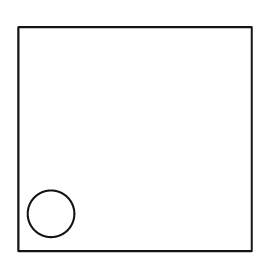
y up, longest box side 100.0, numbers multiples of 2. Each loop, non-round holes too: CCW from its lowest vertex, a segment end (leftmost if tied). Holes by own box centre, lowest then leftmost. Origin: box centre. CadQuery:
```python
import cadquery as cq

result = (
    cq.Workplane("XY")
    .moveTo(-50.0, -48.0)
    .lineTo(50.0, -48.0)
    .lineTo(50.0, 48.0)
    .lineTo(-50.0, 48.0)
    .close()
    .moveTo(-36.0, -32.0)
    .circle(10.0)
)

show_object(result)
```